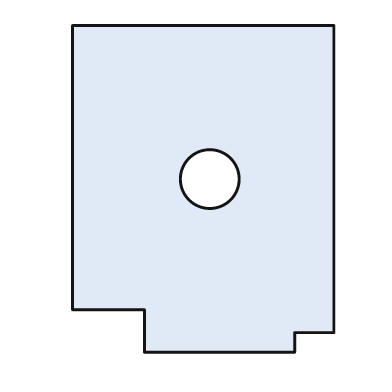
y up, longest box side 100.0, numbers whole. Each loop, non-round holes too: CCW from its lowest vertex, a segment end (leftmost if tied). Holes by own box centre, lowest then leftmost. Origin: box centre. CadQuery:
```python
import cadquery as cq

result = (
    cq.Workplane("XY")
    .moveTo(-18.0, -50.0)
    .lineTo(28.0, -50.0)
    .lineTo(28.0, -44.0)
    .lineTo(40.0, -44.0)
    .lineTo(40.0, 50.0)
    .lineTo(-40.0, 50.0)
    .lineTo(-40.0, -37.0)
    .lineTo(-18.0, -37.0)
    .close()
    .moveTo(2.0, 3.0)
    .circle(9.0)
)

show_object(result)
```